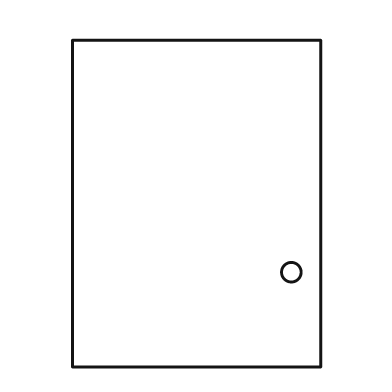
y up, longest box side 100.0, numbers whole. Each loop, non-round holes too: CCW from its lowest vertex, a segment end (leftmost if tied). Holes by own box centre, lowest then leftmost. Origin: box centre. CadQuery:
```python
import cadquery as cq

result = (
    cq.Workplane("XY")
    .moveTo(-38.0, -50.0)
    .lineTo(38.0, -50.0)
    .lineTo(38.0, 50.0)
    .lineTo(-38.0, 50.0)
    .close()
    .moveTo(29.0, -21.0)
    .circle(3.0)
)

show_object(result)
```